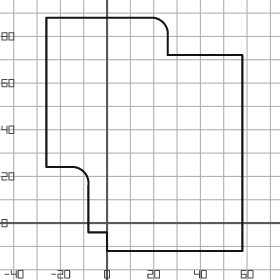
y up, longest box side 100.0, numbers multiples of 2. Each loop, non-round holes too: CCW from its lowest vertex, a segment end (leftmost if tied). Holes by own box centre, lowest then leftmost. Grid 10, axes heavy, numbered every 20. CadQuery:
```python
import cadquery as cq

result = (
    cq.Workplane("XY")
    .moveTo(0.0, -12.0)
    .lineTo(58.0, -12.0)
    .lineTo(58.0, 72.0)
    .lineTo(26.0, 72.0)
    .lineTo(26.0, 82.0)
    .threePointArc((24.0, 86.0), (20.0, 88.0))
    .lineTo(-26.0, 88.0)
    .lineTo(-26.0, 24.0)
    .lineTo(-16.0, 24.0)
    .threePointArc((-10.0, 22.0), (-8.0, 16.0))
    .lineTo(-8.0, -4.0)
    .lineTo(0.0, -4.0)
    .close()
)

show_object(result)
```